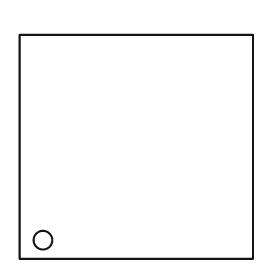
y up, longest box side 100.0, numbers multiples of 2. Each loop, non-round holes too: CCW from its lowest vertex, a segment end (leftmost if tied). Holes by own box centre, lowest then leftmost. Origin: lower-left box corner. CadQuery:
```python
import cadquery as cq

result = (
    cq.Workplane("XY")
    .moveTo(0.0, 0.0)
    .lineTo(100.0, 0.0)
    .lineTo(100.0, 96.0)
    .lineTo(0.0, 96.0)
    .close()
    .moveTo(10.0, 8.0)
    .circle(4.0)
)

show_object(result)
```